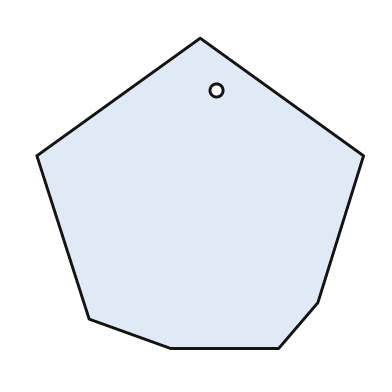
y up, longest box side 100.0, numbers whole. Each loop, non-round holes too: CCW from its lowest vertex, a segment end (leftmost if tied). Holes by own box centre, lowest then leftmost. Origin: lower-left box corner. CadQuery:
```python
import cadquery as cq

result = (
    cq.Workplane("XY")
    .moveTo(41.0, 0.0)
    .lineTo(74.0, 0.0)
    .lineTo(86.0, 14.0)
    .lineTo(100.0, 59.0)
    .lineTo(50.0, 95.0)
    .lineTo(0.0, 59.0)
    .lineTo(16.0, 9.0)
    .close()
    .moveTo(55.0, 79.0)
    .circle(2.0)
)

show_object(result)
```